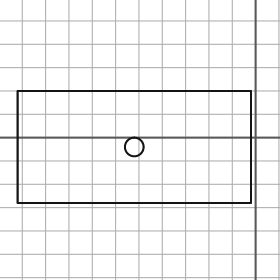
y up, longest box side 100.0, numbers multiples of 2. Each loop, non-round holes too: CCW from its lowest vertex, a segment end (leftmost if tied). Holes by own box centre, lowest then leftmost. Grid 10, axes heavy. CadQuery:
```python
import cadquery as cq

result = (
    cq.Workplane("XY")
    .moveTo(-102.0, -28.0)
    .lineTo(-2.0, -28.0)
    .lineTo(-2.0, 20.0)
    .lineTo(-102.0, 20.0)
    .close()
    .moveTo(-52.0, -4.0)
    .circle(4.0)
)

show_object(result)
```